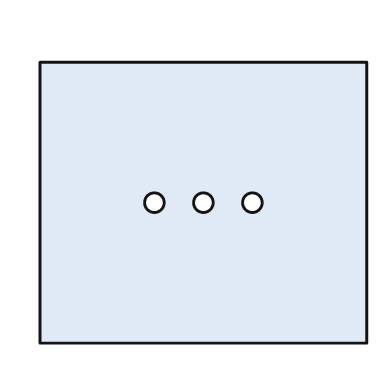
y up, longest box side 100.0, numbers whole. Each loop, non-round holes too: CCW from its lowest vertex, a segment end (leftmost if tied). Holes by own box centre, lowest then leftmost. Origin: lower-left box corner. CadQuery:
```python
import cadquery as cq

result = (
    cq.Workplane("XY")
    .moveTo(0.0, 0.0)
    .lineTo(100.0, 0.0)
    .lineTo(100.0, 86.0)
    .lineTo(0.0, 86.0)
    .close()
    .moveTo(35.0, 43.0)
    .circle(3.0)
    .moveTo(50.0, 43.0)
    .circle(3.0)
    .moveTo(65.0, 43.0)
    .circle(3.0)
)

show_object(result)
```